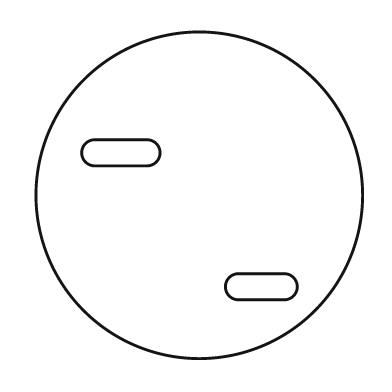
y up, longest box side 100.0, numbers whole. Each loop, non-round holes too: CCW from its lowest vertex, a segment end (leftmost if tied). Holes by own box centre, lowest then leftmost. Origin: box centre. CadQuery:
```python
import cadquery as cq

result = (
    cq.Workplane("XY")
    .moveTo(0.0, 0.0)
    .circle(50.0)
    .moveTo(12.0, -32.0)
    .lineTo(26.0, -32.0)
    .threePointArc((30.0, -28.0), (26.0, -24.0))
    .lineTo(12.0, -24.0)
    .threePointArc((8.0, -28.0), (12.0, -32.0))
    .close()
    .moveTo(-32.0, 9.0)
    .lineTo(-16.0, 9.0)
    .threePointArc((-12.0, 13.0), (-16.0, 17.0))
    .lineTo(-32.0, 17.0)
    .threePointArc((-36.0, 13.0), (-32.0, 9.0))
    .close()
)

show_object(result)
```